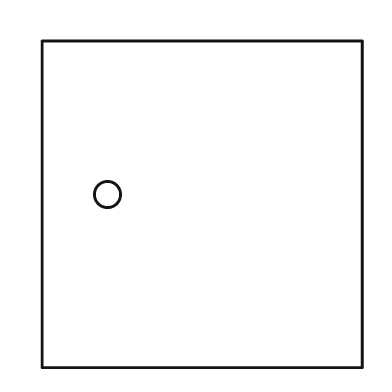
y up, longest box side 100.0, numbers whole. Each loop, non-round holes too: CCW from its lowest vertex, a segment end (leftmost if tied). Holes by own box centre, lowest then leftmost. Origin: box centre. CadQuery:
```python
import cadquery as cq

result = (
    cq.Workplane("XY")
    .moveTo(-49.0, -50.0)
    .lineTo(49.0, -50.0)
    .lineTo(49.0, 50.0)
    .lineTo(-49.0, 50.0)
    .close()
    .moveTo(-29.0, 3.0)
    .circle(4.0)
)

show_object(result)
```